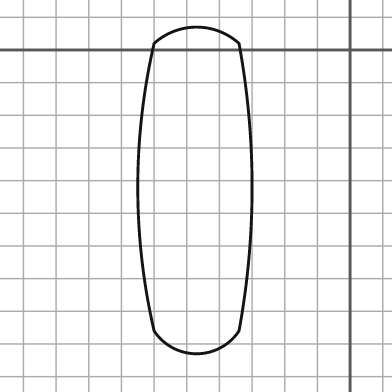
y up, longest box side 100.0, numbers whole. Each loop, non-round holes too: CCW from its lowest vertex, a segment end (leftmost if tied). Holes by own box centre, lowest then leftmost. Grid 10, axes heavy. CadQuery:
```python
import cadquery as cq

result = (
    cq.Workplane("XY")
    .moveTo(-60.0, -86.0)
    .threePointArc((-47.0, -93.0), (-34.0, -86.0))
    .threePointArc((-30.0, -42.0), (-34.0, 2.0))
    .threePointArc((-47.0, 7.0), (-60.0, 2.0))
    .threePointArc((-65.0, -42.0), (-60.0, -86.0))
    .close()
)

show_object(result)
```